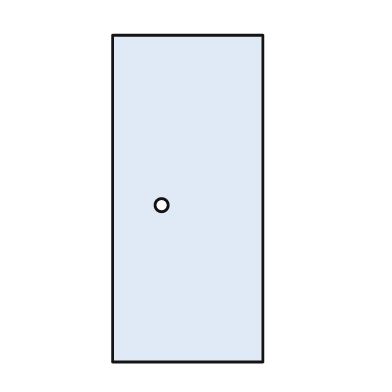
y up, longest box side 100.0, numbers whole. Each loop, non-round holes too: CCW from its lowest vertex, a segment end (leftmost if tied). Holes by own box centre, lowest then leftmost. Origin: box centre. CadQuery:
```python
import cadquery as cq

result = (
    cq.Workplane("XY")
    .moveTo(-23.0, -50.0)
    .lineTo(23.0, -50.0)
    .lineTo(23.0, 50.0)
    .lineTo(-23.0, 50.0)
    .close()
    .moveTo(-8.0, -2.0)
    .circle(2.0)
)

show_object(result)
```